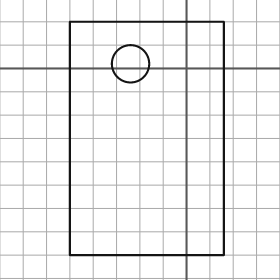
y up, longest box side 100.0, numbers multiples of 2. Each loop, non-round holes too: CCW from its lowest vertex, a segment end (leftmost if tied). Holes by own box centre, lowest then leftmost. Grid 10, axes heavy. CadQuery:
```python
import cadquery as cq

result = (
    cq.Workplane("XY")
    .moveTo(-50.0, -80.0)
    .lineTo(16.0, -80.0)
    .lineTo(16.0, 20.0)
    .lineTo(-50.0, 20.0)
    .close()
    .moveTo(-24.0, 2.0)
    .circle(8.0)
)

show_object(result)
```